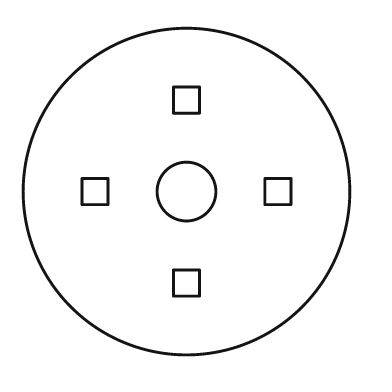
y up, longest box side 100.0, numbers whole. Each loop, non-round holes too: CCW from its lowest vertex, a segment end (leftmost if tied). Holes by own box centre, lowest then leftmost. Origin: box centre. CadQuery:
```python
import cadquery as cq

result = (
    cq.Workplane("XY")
    .moveTo(0.0, 0.0)
    .circle(50.0)
    .moveTo(-4.0, -32.0)
    .lineTo(4.0, -32.0)
    .lineTo(4.0, -24.0)
    .lineTo(-4.0, -24.0)
    .close()
    .moveTo(-32.0, -4.0)
    .lineTo(-24.0, -4.0)
    .lineTo(-24.0, 4.0)
    .lineTo(-32.0, 4.0)
    .close()
    .moveTo(0.0, 0.0)
    .circle(9.0)
    .moveTo(24.0, -4.0)
    .lineTo(32.0, -4.0)
    .lineTo(32.0, 4.0)
    .lineTo(24.0, 4.0)
    .close()
    .moveTo(-4.0, 24.0)
    .lineTo(4.0, 24.0)
    .lineTo(4.0, 32.0)
    .lineTo(-4.0, 32.0)
    .close()
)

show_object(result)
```